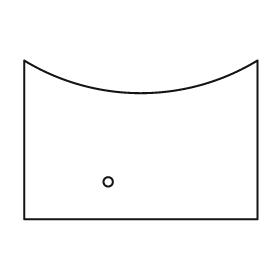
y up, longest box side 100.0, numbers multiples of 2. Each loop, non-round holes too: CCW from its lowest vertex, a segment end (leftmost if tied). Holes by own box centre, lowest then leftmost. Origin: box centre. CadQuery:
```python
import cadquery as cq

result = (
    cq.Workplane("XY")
    .moveTo(-50.0, -34.0)
    .lineTo(50.0, -34.0)
    .lineTo(50.0, 34.0)
    .threePointArc((0.0, 20.0), (-50.0, 34.0))
    .close()
    .moveTo(-14.0, -18.0)
    .circle(2.0)
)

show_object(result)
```